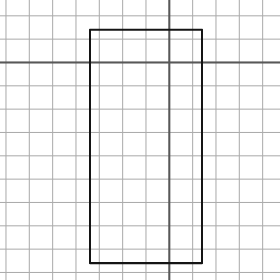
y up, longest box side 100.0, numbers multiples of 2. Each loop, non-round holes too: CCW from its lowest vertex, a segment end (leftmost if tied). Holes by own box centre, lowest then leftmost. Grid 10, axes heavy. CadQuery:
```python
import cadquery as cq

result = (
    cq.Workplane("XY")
    .moveTo(-34.0, -86.0)
    .lineTo(14.0, -86.0)
    .lineTo(14.0, 14.0)
    .lineTo(-34.0, 14.0)
    .close()
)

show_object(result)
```